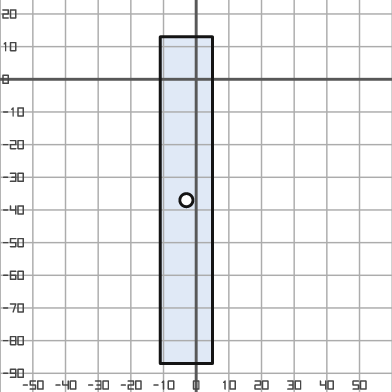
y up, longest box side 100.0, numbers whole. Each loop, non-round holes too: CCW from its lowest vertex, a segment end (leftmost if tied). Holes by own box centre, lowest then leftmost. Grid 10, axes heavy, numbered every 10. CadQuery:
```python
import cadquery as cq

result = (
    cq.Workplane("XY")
    .moveTo(-11.0, -87.0)
    .lineTo(5.0, -87.0)
    .lineTo(5.0, 13.0)
    .lineTo(-11.0, 13.0)
    .close()
    .moveTo(-3.0, -37.0)
    .circle(2.0)
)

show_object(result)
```